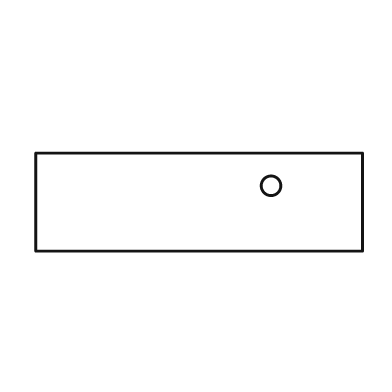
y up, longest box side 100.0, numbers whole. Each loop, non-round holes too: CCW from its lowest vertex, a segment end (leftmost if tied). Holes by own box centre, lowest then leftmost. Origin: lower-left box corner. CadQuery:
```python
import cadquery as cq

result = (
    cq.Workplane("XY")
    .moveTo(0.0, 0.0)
    .lineTo(100.0, 0.0)
    .lineTo(100.0, 30.0)
    .lineTo(0.0, 30.0)
    .close()
    .moveTo(72.0, 20.0)
    .circle(3.0)
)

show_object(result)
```